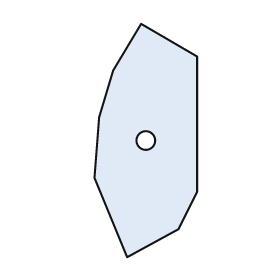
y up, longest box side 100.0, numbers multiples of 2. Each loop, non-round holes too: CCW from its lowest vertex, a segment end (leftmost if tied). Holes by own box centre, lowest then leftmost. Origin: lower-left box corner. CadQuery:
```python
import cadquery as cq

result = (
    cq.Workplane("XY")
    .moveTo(14.0, 0.0)
    .lineTo(36.0, 12.0)
    .lineTo(44.0, 28.0)
    .lineTo(44.0, 86.0)
    .lineTo(20.0, 100.0)
    .lineTo(8.0, 80.0)
    .lineTo(2.0, 60.0)
    .lineTo(0.0, 34.0)
    .close()
    .moveTo(22.0, 50.0)
    .circle(4.0)
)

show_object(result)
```